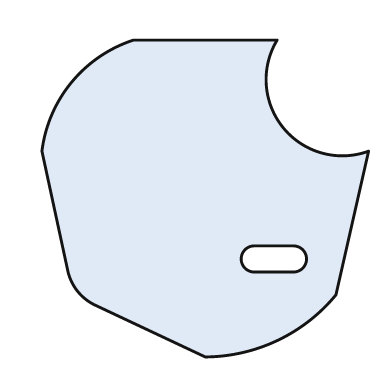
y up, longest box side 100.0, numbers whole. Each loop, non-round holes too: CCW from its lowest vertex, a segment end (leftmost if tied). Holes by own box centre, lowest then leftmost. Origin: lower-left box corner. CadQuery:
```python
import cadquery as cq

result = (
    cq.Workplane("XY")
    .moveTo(50.0, 0.0)
    .threePointArc((72.0, 5.0), (90.0, 19.0))
    .lineTo(100.0, 63.0)
    .threePointArc((74.0, 70.0), (72.0, 97.0))
    .lineTo(28.0, 97.0)
    .threePointArc((9.0, 84.0), (0.0, 63.0))
    .lineTo(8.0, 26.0)
    .threePointArc((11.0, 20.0), (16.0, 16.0))
    .close()
    .moveTo(65.0, 26.0)
    .lineTo(77.0, 26.0)
    .threePointArc((81.0, 30.0), (77.0, 34.0))
    .lineTo(65.0, 34.0)
    .threePointArc((61.0, 30.0), (65.0, 26.0))
    .close()
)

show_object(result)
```